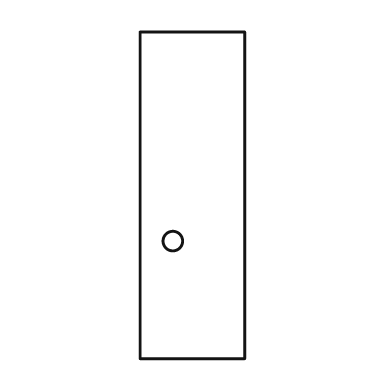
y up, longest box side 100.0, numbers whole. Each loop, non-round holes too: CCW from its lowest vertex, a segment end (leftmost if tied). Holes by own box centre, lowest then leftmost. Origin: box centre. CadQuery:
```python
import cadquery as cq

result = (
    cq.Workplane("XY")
    .moveTo(-16.0, -50.0)
    .lineTo(16.0, -50.0)
    .lineTo(16.0, 50.0)
    .lineTo(-16.0, 50.0)
    .close()
    .moveTo(-6.0, -14.0)
    .circle(3.0)
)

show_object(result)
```